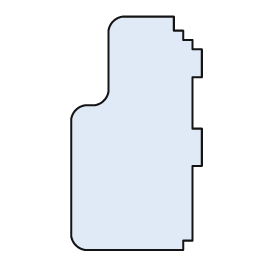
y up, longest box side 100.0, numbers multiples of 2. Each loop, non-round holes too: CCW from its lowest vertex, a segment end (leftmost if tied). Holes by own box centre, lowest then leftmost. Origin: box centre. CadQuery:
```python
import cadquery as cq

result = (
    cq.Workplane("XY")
    .moveTo(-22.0, -50.0)
    .lineTo(20.0, -50.0)
    .lineTo(20.0, -46.0)
    .lineTo(24.0, -46.0)
    .lineTo(24.0, -14.0)
    .lineTo(28.0, -14.0)
    .lineTo(28.0, 2.0)
    .lineTo(24.0, 2.0)
    .lineTo(24.0, 24.0)
    .lineTo(28.0, 24.0)
    .lineTo(28.0, 36.0)
    .lineTo(24.0, 36.0)
    .lineTo(24.0, 40.0)
    .lineTo(20.0, 40.0)
    .lineTo(20.0, 44.0)
    .lineTo(16.0, 44.0)
    .lineTo(16.0, 50.0)
    .lineTo(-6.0, 50.0)
    .threePointArc((-10.0, 48.0), (-12.0, 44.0))
    .lineTo(-12.0, 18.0)
    .threePointArc((-14.0, 14.0), (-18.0, 12.0))
    .lineTo(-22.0, 12.0)
    .threePointArc((-26.0, 10.0), (-28.0, 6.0))
    .lineTo(-28.0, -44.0)
    .threePointArc((-26.0, -48.0), (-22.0, -50.0))
    .close()
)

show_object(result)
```